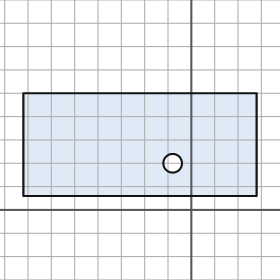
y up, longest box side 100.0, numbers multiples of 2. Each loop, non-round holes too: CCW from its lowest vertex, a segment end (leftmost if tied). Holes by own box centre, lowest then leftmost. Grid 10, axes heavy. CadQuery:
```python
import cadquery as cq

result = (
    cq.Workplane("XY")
    .moveTo(-72.0, 6.0)
    .lineTo(28.0, 6.0)
    .lineTo(28.0, 50.0)
    .lineTo(-72.0, 50.0)
    .close()
    .moveTo(-8.0, 20.0)
    .circle(4.0)
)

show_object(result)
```